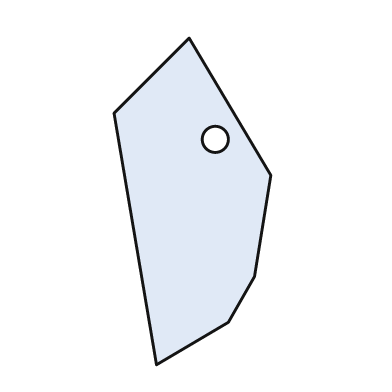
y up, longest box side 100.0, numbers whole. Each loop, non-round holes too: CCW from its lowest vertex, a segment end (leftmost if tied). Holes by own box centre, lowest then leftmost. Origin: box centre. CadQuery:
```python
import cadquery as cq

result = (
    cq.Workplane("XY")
    .moveTo(-11.0, -50.0)
    .lineTo(11.0, -37.0)
    .lineTo(19.0, -23.0)
    .lineTo(24.0, 8.0)
    .lineTo(-1.0, 50.0)
    .lineTo(-24.0, 27.0)
    .close()
    .moveTo(7.0, 19.0)
    .circle(4.0)
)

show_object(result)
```